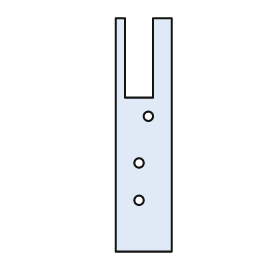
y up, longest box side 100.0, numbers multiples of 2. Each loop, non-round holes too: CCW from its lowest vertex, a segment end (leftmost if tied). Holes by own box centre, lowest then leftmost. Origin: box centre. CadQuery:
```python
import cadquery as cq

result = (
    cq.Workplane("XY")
    .moveTo(-12.0, -50.0)
    .lineTo(12.0, -50.0)
    .lineTo(12.0, 50.0)
    .lineTo(4.0, 50.0)
    .lineTo(4.0, 16.0)
    .lineTo(-8.0, 16.0)
    .lineTo(-8.0, 50.0)
    .lineTo(-12.0, 50.0)
    .close()
    .moveTo(-2.0, -28.0)
    .circle(2.0)
    .moveTo(-2.0, -12.0)
    .circle(2.0)
    .moveTo(2.0, 8.0)
    .circle(2.0)
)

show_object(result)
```